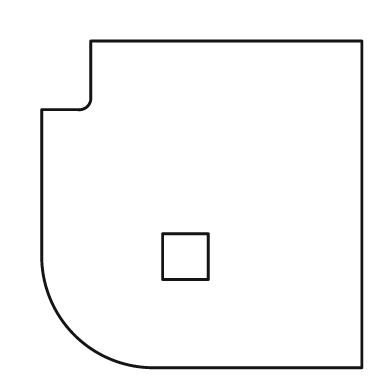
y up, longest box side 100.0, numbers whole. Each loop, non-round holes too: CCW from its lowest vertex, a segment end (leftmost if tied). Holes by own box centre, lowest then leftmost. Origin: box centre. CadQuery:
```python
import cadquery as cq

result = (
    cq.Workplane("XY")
    .moveTo(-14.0, -50.0)
    .lineTo(49.0, -50.0)
    .lineTo(49.0, 50.0)
    .lineTo(-34.0, 50.0)
    .lineTo(-34.0, 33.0)
    .threePointArc((-35.0, 30.0), (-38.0, 29.0))
    .lineTo(-49.0, 29.0)
    .lineTo(-49.0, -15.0)
    .threePointArc((-39.0, -40.0), (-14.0, -50.0))
    .close()
    .moveTo(-12.0, -23.0)
    .lineTo(2.0, -23.0)
    .lineTo(2.0, -9.0)
    .lineTo(-12.0, -9.0)
    .close()
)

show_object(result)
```